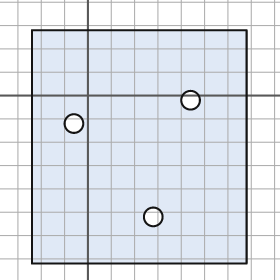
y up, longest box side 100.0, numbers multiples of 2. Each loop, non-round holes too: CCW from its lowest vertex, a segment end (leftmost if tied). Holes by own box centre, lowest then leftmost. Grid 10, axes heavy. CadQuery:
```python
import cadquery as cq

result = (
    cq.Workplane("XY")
    .moveTo(-24.0, -72.0)
    .lineTo(68.0, -72.0)
    .lineTo(68.0, 28.0)
    .lineTo(-24.0, 28.0)
    .close()
    .moveTo(28.0, -52.0)
    .circle(4.0)
    .moveTo(-6.0, -12.0)
    .circle(4.0)
    .moveTo(44.0, -2.0)
    .circle(4.0)
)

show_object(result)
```